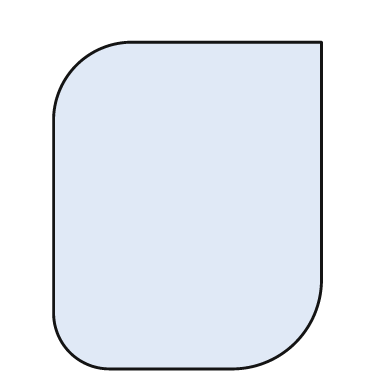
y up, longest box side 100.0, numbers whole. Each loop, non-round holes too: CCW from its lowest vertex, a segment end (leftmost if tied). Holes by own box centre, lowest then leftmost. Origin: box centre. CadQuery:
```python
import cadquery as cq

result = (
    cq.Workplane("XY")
    .moveTo(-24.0, -50.0)
    .lineTo(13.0, -50.0)
    .threePointArc((33.0, -42.0), (41.0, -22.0))
    .lineTo(41.0, 50.0)
    .lineTo(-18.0, 50.0)
    .threePointArc((-34.0, 43.0), (-41.0, 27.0))
    .lineTo(-41.0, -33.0)
    .threePointArc((-36.0, -45.0), (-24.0, -50.0))
    .close()
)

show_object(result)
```